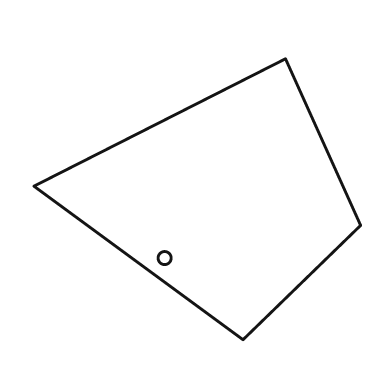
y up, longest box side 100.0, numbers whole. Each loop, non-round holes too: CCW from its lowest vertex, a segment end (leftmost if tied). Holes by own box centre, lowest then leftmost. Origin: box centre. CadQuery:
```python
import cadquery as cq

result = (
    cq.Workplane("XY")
    .moveTo(14.0, -43.0)
    .lineTo(50.0, -8.0)
    .lineTo(27.0, 43.0)
    .lineTo(-50.0, 4.0)
    .close()
    .moveTo(-10.0, -18.0)
    .circle(2.0)
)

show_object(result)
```